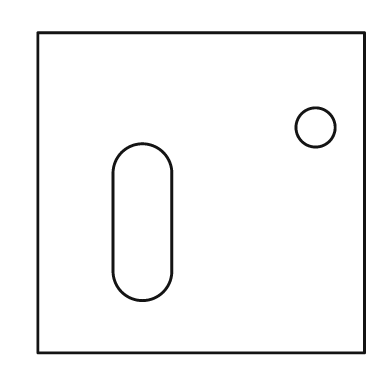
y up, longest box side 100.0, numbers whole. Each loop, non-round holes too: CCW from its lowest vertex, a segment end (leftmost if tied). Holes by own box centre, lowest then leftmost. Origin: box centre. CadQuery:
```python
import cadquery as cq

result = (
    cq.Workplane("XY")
    .moveTo(-50.0, -49.0)
    .lineTo(50.0, -49.0)
    .lineTo(50.0, 49.0)
    .lineTo(-50.0, 49.0)
    .close()
    .moveTo(-27.0, -24.0)
    .threePointArc((-18.0, -33.0), (-9.0, -24.0))
    .lineTo(-9.0, 6.0)
    .threePointArc((-18.0, 15.0), (-27.0, 6.0))
    .close()
    .moveTo(35.0, 20.0)
    .circle(6.0)
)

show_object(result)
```